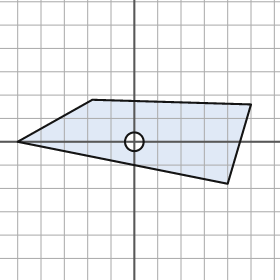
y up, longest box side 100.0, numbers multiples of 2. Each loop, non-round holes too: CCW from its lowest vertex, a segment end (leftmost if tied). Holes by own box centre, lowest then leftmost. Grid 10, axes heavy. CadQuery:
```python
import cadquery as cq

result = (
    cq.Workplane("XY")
    .moveTo(40.0, -18.0)
    .lineTo(50.0, 16.0)
    .lineTo(-18.0, 18.0)
    .lineTo(-50.0, 0.0)
    .close()
    .moveTo(0.0, 0.0)
    .circle(4.0)
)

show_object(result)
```